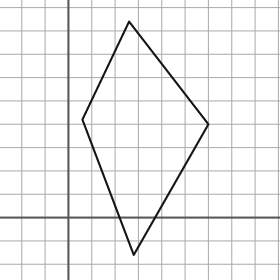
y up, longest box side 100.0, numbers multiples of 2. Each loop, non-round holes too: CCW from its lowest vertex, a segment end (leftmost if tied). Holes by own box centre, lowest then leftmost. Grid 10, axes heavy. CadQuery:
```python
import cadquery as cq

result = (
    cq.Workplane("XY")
    .moveTo(28.0, -16.0)
    .lineTo(60.0, 40.0)
    .lineTo(26.0, 84.0)
    .lineTo(6.0, 42.0)
    .close()
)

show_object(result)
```